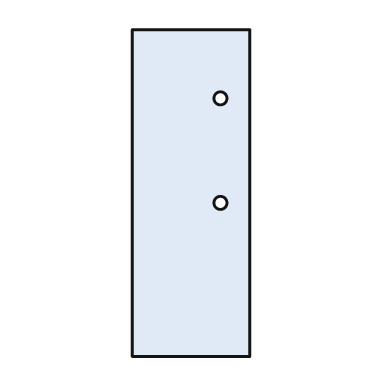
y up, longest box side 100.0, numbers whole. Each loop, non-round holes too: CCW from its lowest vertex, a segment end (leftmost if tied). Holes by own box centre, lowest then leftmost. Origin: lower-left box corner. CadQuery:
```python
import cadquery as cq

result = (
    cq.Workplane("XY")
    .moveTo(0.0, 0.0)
    .lineTo(36.0, 0.0)
    .lineTo(36.0, 100.0)
    .lineTo(0.0, 100.0)
    .close()
    .moveTo(27.0, 47.0)
    .circle(2.0)
    .moveTo(27.0, 79.0)
    .circle(2.0)
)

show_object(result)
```